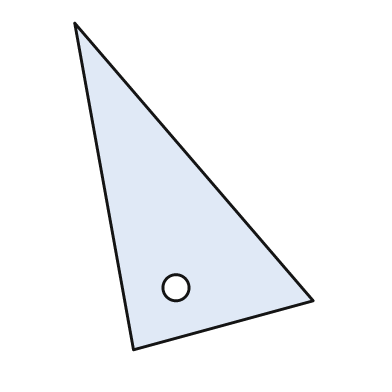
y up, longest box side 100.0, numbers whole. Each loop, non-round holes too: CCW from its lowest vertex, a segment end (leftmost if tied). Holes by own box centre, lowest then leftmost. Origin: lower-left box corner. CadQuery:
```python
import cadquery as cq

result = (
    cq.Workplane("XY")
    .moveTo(18.0, 0.0)
    .lineTo(73.0, 15.0)
    .lineTo(0.0, 100.0)
    .close()
    .moveTo(31.0, 19.0)
    .circle(4.0)
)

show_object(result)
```